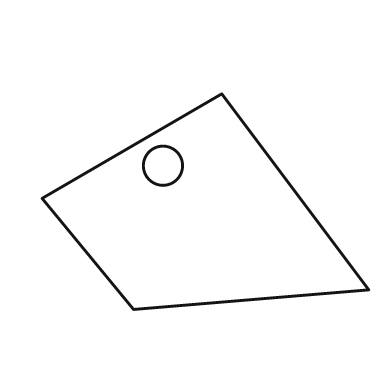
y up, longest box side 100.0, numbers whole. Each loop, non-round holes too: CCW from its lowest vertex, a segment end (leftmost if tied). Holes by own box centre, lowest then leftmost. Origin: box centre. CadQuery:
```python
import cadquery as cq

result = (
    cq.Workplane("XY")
    .moveTo(-22.0, -33.0)
    .lineTo(50.0, -27.0)
    .lineTo(5.0, 33.0)
    .lineTo(-50.0, 1.0)
    .close()
    .moveTo(-13.0, 11.0)
    .circle(6.0)
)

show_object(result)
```